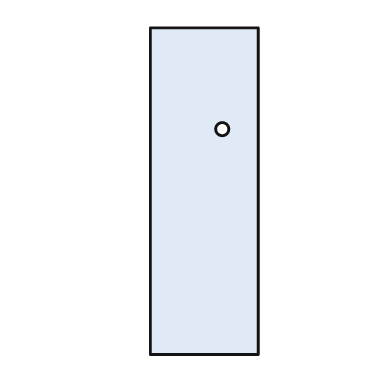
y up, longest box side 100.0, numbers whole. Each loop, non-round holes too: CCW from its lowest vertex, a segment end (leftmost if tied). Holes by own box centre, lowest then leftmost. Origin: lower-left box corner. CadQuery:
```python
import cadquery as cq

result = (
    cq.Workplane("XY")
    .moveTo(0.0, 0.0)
    .lineTo(33.0, 0.0)
    .lineTo(33.0, 100.0)
    .lineTo(0.0, 100.0)
    .close()
    .moveTo(22.0, 69.0)
    .circle(2.0)
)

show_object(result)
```